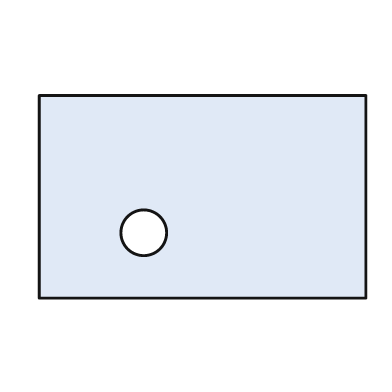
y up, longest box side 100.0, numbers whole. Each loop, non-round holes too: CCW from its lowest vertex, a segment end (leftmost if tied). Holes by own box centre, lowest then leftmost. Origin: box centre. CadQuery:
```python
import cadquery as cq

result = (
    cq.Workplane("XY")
    .moveTo(-50.0, -31.0)
    .lineTo(50.0, -31.0)
    .lineTo(50.0, 31.0)
    .lineTo(-50.0, 31.0)
    .close()
    .moveTo(-18.0, -11.0)
    .circle(7.0)
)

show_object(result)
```